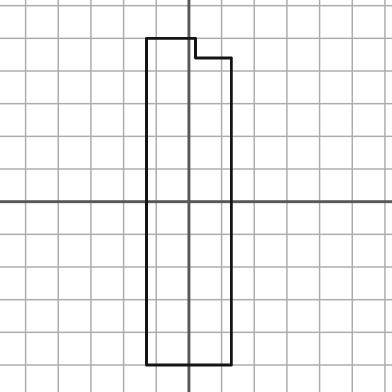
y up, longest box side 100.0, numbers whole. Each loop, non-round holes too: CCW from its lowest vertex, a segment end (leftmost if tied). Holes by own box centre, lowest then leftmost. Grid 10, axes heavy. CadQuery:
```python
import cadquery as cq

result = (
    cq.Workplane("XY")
    .moveTo(-13.0, -50.0)
    .lineTo(13.0, -50.0)
    .lineTo(13.0, 44.0)
    .lineTo(2.0, 44.0)
    .lineTo(2.0, 50.0)
    .lineTo(-13.0, 50.0)
    .close()
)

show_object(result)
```